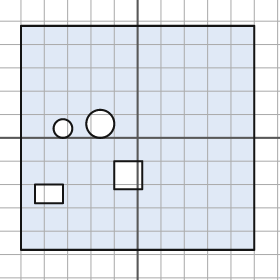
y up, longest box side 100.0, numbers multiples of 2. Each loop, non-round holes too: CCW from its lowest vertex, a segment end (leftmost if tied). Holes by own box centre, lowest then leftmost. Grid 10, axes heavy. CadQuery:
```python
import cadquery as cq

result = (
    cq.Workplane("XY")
    .moveTo(-50.0, -48.0)
    .lineTo(50.0, -48.0)
    .lineTo(50.0, 48.0)
    .lineTo(-50.0, 48.0)
    .close()
    .moveTo(-44.0, -28.0)
    .lineTo(-32.0, -28.0)
    .lineTo(-32.0, -20.0)
    .lineTo(-44.0, -20.0)
    .close()
    .moveTo(-10.0, -22.0)
    .lineTo(2.0, -22.0)
    .lineTo(2.0, -10.0)
    .lineTo(-10.0, -10.0)
    .close()
    .moveTo(-32.0, 4.0)
    .circle(4.0)
    .moveTo(-16.0, 6.0)
    .circle(6.0)
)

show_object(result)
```